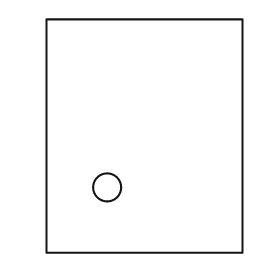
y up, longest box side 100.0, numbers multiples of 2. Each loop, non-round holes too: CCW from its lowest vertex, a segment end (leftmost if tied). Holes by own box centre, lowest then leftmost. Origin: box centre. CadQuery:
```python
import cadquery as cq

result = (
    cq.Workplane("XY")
    .moveTo(-42.0, -50.0)
    .lineTo(42.0, -50.0)
    .lineTo(42.0, 50.0)
    .lineTo(-42.0, 50.0)
    .close()
    .moveTo(-16.0, -22.0)
    .circle(6.0)
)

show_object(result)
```